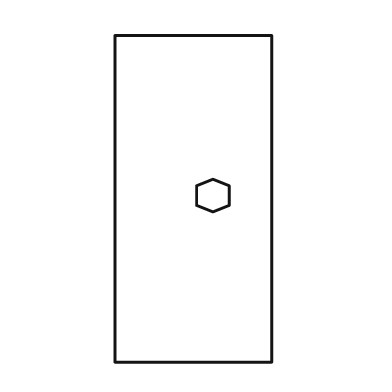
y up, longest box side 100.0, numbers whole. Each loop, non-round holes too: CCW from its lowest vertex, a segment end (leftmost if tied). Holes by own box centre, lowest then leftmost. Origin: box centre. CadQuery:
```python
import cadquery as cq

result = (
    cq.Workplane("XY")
    .moveTo(-24.0, -50.0)
    .lineTo(24.0, -50.0)
    .lineTo(24.0, 50.0)
    .lineTo(-24.0, 50.0)
    .close()
    .moveTo(6.0, -4.0)
    .lineTo(11.0, -2.0)
    .lineTo(11.0, 4.0)
    .lineTo(6.0, 6.0)
    .lineTo(1.0, 4.0)
    .lineTo(1.0, -2.0)
    .close()
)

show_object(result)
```